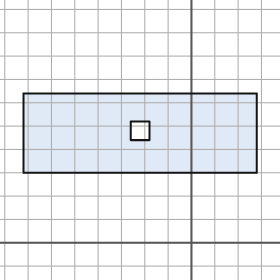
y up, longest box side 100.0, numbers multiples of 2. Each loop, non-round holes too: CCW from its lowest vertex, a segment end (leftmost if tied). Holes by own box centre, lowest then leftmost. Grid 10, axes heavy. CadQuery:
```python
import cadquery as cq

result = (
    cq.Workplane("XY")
    .moveTo(-72.0, 30.0)
    .lineTo(28.0, 30.0)
    .lineTo(28.0, 64.0)
    .lineTo(-72.0, 64.0)
    .close()
    .moveTo(-26.0, 44.0)
    .lineTo(-18.0, 44.0)
    .lineTo(-18.0, 52.0)
    .lineTo(-26.0, 52.0)
    .close()
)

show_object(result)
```